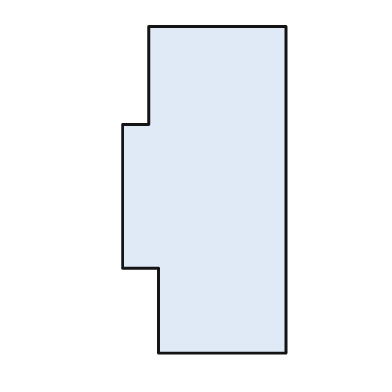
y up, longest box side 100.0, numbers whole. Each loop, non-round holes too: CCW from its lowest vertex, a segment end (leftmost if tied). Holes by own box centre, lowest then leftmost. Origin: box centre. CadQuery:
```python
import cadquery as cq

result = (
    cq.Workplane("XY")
    .moveTo(-14.0, -50.0)
    .lineTo(25.0, -50.0)
    .lineTo(25.0, 50.0)
    .lineTo(-17.0, 50.0)
    .lineTo(-17.0, 20.0)
    .lineTo(-25.0, 20.0)
    .lineTo(-25.0, -24.0)
    .lineTo(-14.0, -24.0)
    .close()
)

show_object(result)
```